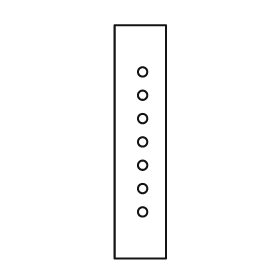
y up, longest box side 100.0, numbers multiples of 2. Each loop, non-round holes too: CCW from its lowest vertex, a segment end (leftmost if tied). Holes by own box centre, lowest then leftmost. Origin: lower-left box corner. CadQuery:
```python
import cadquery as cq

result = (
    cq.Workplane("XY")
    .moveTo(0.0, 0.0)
    .lineTo(22.0, 0.0)
    .lineTo(22.0, 100.0)
    .lineTo(0.0, 100.0)
    .close()
    .moveTo(12.0, 20.0)
    .circle(2.0)
    .moveTo(12.0, 30.0)
    .circle(2.0)
    .moveTo(12.0, 40.0)
    .circle(2.0)
    .moveTo(12.0, 50.0)
    .circle(2.0)
    .moveTo(12.0, 60.0)
    .circle(2.0)
    .moveTo(12.0, 70.0)
    .circle(2.0)
    .moveTo(12.0, 80.0)
    .circle(2.0)
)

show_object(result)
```